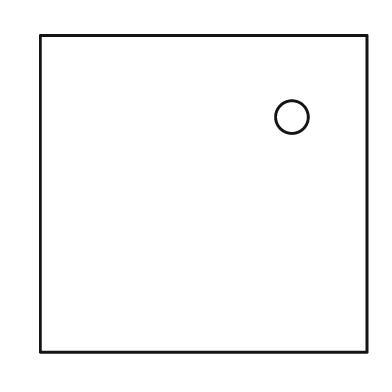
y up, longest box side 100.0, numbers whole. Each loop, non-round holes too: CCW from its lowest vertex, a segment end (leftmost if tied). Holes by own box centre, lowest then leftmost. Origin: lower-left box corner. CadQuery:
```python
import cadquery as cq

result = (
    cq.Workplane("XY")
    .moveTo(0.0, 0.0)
    .lineTo(100.0, 0.0)
    .lineTo(100.0, 97.0)
    .lineTo(0.0, 97.0)
    .close()
    .moveTo(77.0, 72.0)
    .circle(5.0)
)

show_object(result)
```